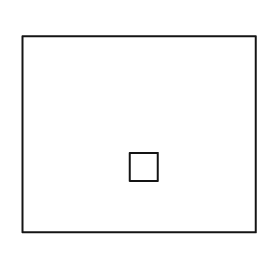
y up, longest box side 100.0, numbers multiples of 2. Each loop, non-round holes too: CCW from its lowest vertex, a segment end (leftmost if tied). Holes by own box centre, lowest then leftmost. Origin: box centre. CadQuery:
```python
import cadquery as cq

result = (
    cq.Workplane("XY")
    .moveTo(-50.0, -42.0)
    .lineTo(50.0, -42.0)
    .lineTo(50.0, 42.0)
    .lineTo(-50.0, 42.0)
    .close()
    .moveTo(-4.0, -20.0)
    .lineTo(8.0, -20.0)
    .lineTo(8.0, -8.0)
    .lineTo(-4.0, -8.0)
    .close()
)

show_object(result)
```